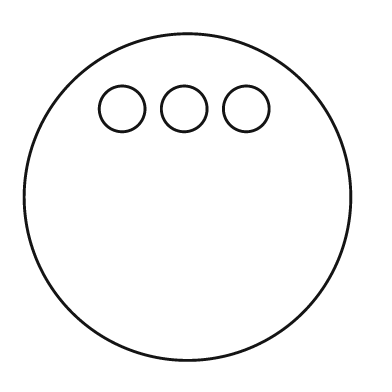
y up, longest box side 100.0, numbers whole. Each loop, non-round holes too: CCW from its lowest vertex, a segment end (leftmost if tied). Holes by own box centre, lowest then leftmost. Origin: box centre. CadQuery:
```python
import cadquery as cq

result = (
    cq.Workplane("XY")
    .moveTo(0.0, 0.0)
    .circle(50.0)
    .moveTo(-20.0, 27.0)
    .circle(7.0)
    .moveTo(-1.0, 27.0)
    .circle(7.0)
    .moveTo(18.0, 27.0)
    .circle(7.0)
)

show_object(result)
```